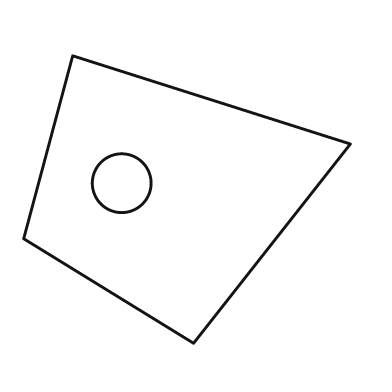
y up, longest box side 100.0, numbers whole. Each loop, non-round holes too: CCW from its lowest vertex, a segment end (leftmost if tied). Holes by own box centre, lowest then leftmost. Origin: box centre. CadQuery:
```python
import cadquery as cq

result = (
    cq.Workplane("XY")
    .moveTo(2.0, -44.0)
    .lineTo(50.0, 17.0)
    .lineTo(-35.0, 44.0)
    .lineTo(-50.0, -12.0)
    .close()
    .moveTo(-20.0, 5.0)
    .circle(9.0)
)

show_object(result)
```